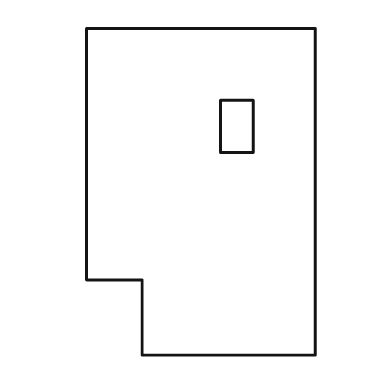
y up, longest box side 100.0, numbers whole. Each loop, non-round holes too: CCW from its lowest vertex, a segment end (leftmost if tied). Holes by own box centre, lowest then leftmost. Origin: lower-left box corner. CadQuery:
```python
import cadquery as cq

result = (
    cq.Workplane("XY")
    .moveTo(17.0, 0.0)
    .lineTo(70.0, 0.0)
    .lineTo(70.0, 100.0)
    .lineTo(0.0, 100.0)
    .lineTo(0.0, 23.0)
    .lineTo(17.0, 23.0)
    .close()
    .moveTo(41.0, 62.0)
    .lineTo(51.0, 62.0)
    .lineTo(51.0, 78.0)
    .lineTo(41.0, 78.0)
    .close()
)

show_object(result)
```